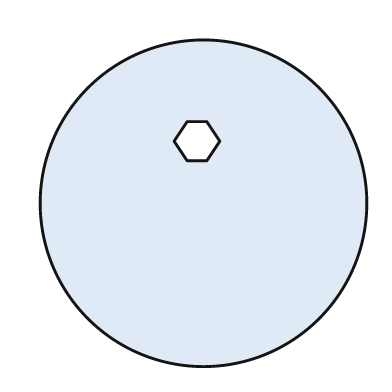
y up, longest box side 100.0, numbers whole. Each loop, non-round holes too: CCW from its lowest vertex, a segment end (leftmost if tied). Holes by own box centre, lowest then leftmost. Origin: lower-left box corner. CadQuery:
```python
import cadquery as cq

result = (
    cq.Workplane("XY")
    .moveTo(50.0, 50.0)
    .circle(50.0)
    .moveTo(45.0, 63.0)
    .lineTo(51.0, 63.0)
    .lineTo(55.0, 69.0)
    .lineTo(51.0, 75.0)
    .lineTo(45.0, 75.0)
    .lineTo(41.0, 69.0)
    .close()
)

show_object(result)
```